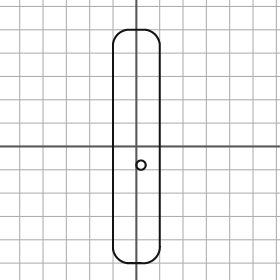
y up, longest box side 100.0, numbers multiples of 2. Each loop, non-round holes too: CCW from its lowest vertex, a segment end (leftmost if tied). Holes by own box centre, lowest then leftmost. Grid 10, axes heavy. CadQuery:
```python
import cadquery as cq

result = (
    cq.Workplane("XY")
    .moveTo(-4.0, -50.0)
    .lineTo(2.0, -50.0)
    .threePointArc((8.0, -48.0), (10.0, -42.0))
    .lineTo(10.0, 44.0)
    .threePointArc((8.0, 48.0), (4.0, 50.0))
    .lineTo(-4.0, 50.0)
    .threePointArc((-8.0, 48.0), (-10.0, 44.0))
    .lineTo(-10.0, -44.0)
    .threePointArc((-8.0, -48.0), (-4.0, -50.0))
    .close()
    .moveTo(2.0, -8.0)
    .circle(2.0)
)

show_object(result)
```